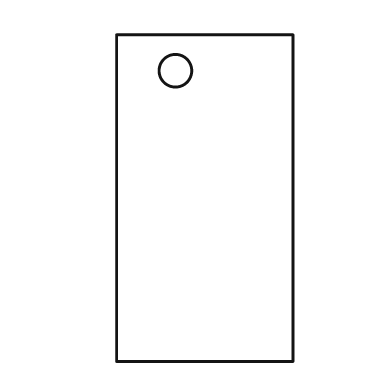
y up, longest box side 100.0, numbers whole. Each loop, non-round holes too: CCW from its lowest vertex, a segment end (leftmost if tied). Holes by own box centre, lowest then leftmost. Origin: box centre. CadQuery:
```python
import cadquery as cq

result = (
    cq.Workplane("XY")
    .moveTo(-27.0, -50.0)
    .lineTo(27.0, -50.0)
    .lineTo(27.0, 50.0)
    .lineTo(-27.0, 50.0)
    .close()
    .moveTo(-9.0, 39.0)
    .circle(5.0)
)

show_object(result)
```